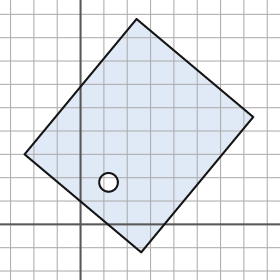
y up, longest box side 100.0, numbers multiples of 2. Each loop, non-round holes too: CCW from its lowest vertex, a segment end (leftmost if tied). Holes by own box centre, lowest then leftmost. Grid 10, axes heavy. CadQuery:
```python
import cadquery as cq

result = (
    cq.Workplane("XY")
    .moveTo(26.0, -12.0)
    .lineTo(74.0, 46.0)
    .lineTo(24.0, 88.0)
    .lineTo(-24.0, 30.0)
    .close()
    .moveTo(12.0, 18.0)
    .circle(4.0)
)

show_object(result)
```